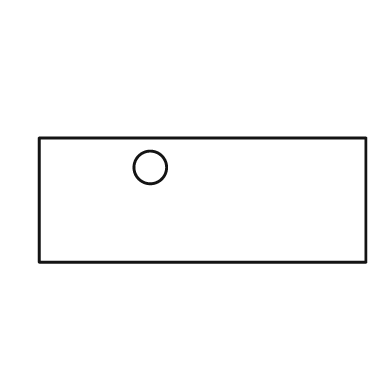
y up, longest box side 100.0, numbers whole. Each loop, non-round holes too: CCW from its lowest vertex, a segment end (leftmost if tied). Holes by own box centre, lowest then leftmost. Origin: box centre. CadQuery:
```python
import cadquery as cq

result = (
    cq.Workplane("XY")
    .moveTo(-50.0, -19.0)
    .lineTo(50.0, -19.0)
    .lineTo(50.0, 19.0)
    .lineTo(-50.0, 19.0)
    .close()
    .moveTo(-16.0, 10.0)
    .circle(5.0)
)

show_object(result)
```